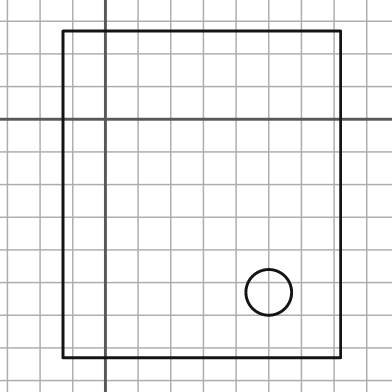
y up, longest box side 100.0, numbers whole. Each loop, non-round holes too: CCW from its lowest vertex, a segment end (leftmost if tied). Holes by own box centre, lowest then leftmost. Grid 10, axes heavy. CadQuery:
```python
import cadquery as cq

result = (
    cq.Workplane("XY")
    .moveTo(-13.0, -73.0)
    .lineTo(72.0, -73.0)
    .lineTo(72.0, 27.0)
    .lineTo(-13.0, 27.0)
    .close()
    .moveTo(50.0, -53.0)
    .circle(7.0)
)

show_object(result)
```